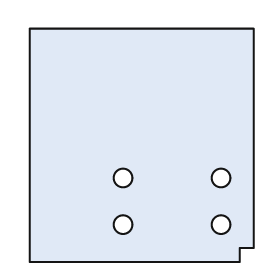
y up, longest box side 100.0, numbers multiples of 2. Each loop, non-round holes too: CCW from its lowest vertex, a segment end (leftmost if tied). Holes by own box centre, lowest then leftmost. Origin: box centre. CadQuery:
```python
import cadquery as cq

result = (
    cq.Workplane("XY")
    .moveTo(-48.0, -50.0)
    .lineTo(42.0, -50.0)
    .lineTo(42.0, -44.0)
    .lineTo(48.0, -44.0)
    .lineTo(48.0, 50.0)
    .lineTo(-48.0, 50.0)
    .close()
    .moveTo(-8.0, -34.0)
    .circle(4.0)
    .moveTo(34.0, -34.0)
    .circle(4.0)
    .moveTo(-8.0, -14.0)
    .circle(4.0)
    .moveTo(34.0, -14.0)
    .circle(4.0)
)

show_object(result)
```